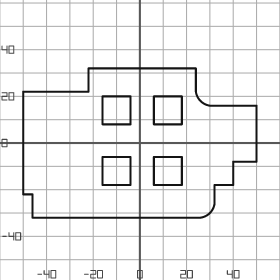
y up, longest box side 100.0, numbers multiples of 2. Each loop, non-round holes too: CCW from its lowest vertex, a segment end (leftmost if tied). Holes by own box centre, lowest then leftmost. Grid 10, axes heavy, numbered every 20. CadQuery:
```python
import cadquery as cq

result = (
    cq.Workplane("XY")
    .moveTo(-46.0, -32.0)
    .lineTo(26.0, -32.0)
    .threePointArc((30.0, -30.0), (32.0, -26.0))
    .lineTo(32.0, -18.0)
    .lineTo(40.0, -18.0)
    .lineTo(40.0, -8.0)
    .lineTo(50.0, -8.0)
    .lineTo(50.0, 16.0)
    .lineTo(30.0, 16.0)
    .threePointArc((26.0, 18.0), (24.0, 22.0))
    .lineTo(24.0, 32.0)
    .lineTo(-22.0, 32.0)
    .lineTo(-22.0, 22.0)
    .lineTo(-50.0, 22.0)
    .lineTo(-50.0, -22.0)
    .lineTo(-46.0, -22.0)
    .close()
    .moveTo(-16.0, -18.0)
    .lineTo(-4.0, -18.0)
    .lineTo(-4.0, -6.0)
    .lineTo(-16.0, -6.0)
    .close()
    .moveTo(6.0, -18.0)
    .lineTo(18.0, -18.0)
    .lineTo(18.0, -6.0)
    .lineTo(6.0, -6.0)
    .close()
    .moveTo(-16.0, 8.0)
    .lineTo(-4.0, 8.0)
    .lineTo(-4.0, 20.0)
    .lineTo(-16.0, 20.0)
    .close()
    .moveTo(6.0, 8.0)
    .lineTo(18.0, 8.0)
    .lineTo(18.0, 20.0)
    .lineTo(6.0, 20.0)
    .close()
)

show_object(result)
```